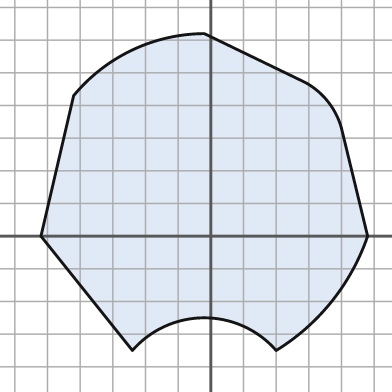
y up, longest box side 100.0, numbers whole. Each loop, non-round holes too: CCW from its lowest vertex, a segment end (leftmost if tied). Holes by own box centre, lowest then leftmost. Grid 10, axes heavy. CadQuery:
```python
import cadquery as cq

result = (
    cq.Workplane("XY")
    .moveTo(-24.0, -35.0)
    .threePointArc((-2.0, -25.0), (20.0, -35.0))
    .threePointArc((37.0, -20.0), (48.0, 0.0))
    .lineTo(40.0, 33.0)
    .threePointArc((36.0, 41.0), (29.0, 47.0))
    .lineTo(-2.0, 62.0)
    .threePointArc((-24.0, 57.0), (-42.0, 43.0))
    .lineTo(-52.0, 0.0)
    .close()
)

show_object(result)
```